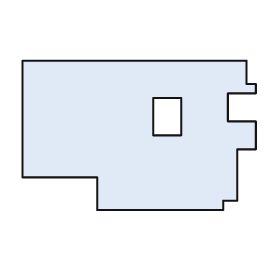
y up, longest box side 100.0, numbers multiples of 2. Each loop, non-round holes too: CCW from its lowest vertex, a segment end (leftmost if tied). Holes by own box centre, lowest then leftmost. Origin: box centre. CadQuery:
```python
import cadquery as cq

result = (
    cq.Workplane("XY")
    .moveTo(-18.0, -32.0)
    .lineTo(36.0, -32.0)
    .lineTo(36.0, -28.0)
    .lineTo(42.0, -28.0)
    .lineTo(42.0, -6.0)
    .lineTo(50.0, -6.0)
    .lineTo(50.0, 6.0)
    .lineTo(38.0, 6.0)
    .lineTo(38.0, 18.0)
    .lineTo(50.0, 18.0)
    .lineTo(50.0, 22.0)
    .lineTo(46.0, 22.0)
    .lineTo(46.0, 32.0)
    .lineTo(-50.0, 32.0)
    .lineTo(-50.0, -18.0)
    .lineTo(-18.0, -18.0)
    .close()
    .moveTo(6.0, 0.0)
    .lineTo(18.0, 0.0)
    .lineTo(18.0, 16.0)
    .lineTo(6.0, 16.0)
    .close()
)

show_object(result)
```